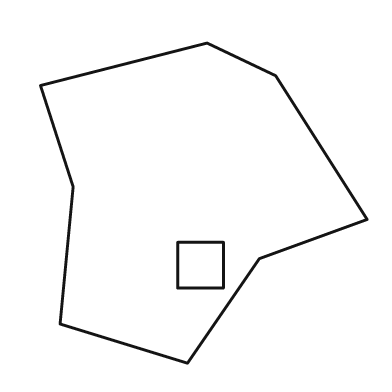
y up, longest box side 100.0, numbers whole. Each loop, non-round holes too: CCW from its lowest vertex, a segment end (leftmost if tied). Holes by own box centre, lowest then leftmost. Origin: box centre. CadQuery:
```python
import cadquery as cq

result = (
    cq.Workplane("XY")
    .moveTo(-5.0, -49.0)
    .lineTo(17.0, -17.0)
    .lineTo(50.0, -5.0)
    .lineTo(22.0, 39.0)
    .lineTo(1.0, 49.0)
    .lineTo(-50.0, 36.0)
    .lineTo(-40.0, 5.0)
    .lineTo(-44.0, -37.0)
    .close()
    .moveTo(-8.0, -26.0)
    .lineTo(6.0, -26.0)
    .lineTo(6.0, -12.0)
    .lineTo(-8.0, -12.0)
    .close()
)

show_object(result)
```